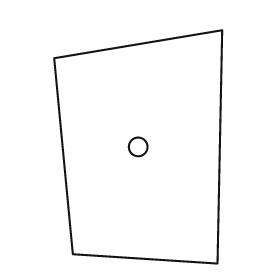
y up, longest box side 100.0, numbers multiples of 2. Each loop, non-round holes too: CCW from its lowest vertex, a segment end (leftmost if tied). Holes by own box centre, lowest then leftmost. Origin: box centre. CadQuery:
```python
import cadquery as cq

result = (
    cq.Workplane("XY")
    .moveTo(34.0, -50.0)
    .lineTo(36.0, 50.0)
    .lineTo(-36.0, 38.0)
    .lineTo(-28.0, -46.0)
    .close()
    .moveTo(0.0, 0.0)
    .circle(4.0)
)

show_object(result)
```